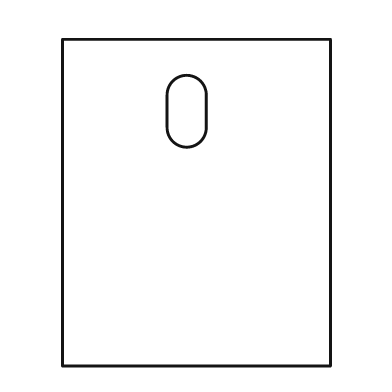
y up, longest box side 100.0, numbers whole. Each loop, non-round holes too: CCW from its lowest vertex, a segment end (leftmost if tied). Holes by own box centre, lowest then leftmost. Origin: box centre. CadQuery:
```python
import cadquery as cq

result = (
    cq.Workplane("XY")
    .moveTo(-41.0, -50.0)
    .lineTo(41.0, -50.0)
    .lineTo(41.0, 50.0)
    .lineTo(-41.0, 50.0)
    .close()
    .moveTo(-9.0, 23.0)
    .threePointArc((-3.0, 17.0), (3.0, 23.0))
    .lineTo(3.0, 33.0)
    .threePointArc((-3.0, 39.0), (-9.0, 33.0))
    .close()
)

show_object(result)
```